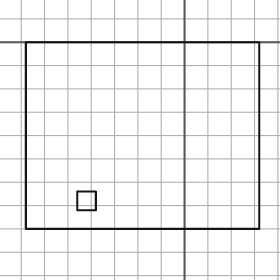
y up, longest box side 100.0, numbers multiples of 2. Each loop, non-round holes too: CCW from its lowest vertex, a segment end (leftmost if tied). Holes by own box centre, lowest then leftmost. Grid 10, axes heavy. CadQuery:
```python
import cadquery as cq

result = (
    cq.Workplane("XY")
    .moveTo(-68.0, -80.0)
    .lineTo(32.0, -80.0)
    .lineTo(32.0, 0.0)
    .lineTo(-68.0, 0.0)
    .close()
    .moveTo(-46.0, -72.0)
    .lineTo(-38.0, -72.0)
    .lineTo(-38.0, -64.0)
    .lineTo(-46.0, -64.0)
    .close()
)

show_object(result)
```